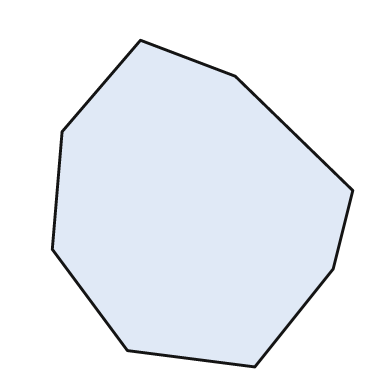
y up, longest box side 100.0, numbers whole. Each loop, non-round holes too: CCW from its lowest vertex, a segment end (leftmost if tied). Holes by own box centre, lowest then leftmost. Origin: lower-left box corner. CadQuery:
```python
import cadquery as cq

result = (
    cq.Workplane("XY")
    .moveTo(62.0, 0.0)
    .lineTo(86.0, 30.0)
    .lineTo(92.0, 54.0)
    .lineTo(56.0, 89.0)
    .lineTo(27.0, 100.0)
    .lineTo(3.0, 72.0)
    .lineTo(0.0, 36.0)
    .lineTo(23.0, 5.0)
    .close()
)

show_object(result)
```